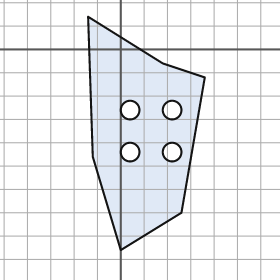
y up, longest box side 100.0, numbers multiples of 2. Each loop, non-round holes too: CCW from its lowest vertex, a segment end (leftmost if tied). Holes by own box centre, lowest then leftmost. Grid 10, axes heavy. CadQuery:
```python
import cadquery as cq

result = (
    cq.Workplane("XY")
    .moveTo(0.0, -86.0)
    .lineTo(26.0, -70.0)
    .lineTo(36.0, -12.0)
    .lineTo(18.0, -6.0)
    .lineTo(-14.0, 14.0)
    .lineTo(-12.0, -46.0)
    .close()
    .moveTo(4.0, -44.0)
    .circle(4.0)
    .moveTo(22.0, -44.0)
    .circle(4.0)
    .moveTo(4.0, -26.0)
    .circle(4.0)
    .moveTo(22.0, -26.0)
    .circle(4.0)
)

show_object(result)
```